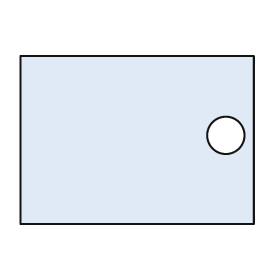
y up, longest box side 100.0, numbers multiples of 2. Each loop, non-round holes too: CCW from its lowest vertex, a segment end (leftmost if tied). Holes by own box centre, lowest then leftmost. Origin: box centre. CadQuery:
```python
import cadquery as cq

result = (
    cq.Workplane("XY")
    .moveTo(-50.0, -36.0)
    .lineTo(50.0, -36.0)
    .lineTo(50.0, 36.0)
    .lineTo(-50.0, 36.0)
    .close()
    .moveTo(38.0, 2.0)
    .circle(8.0)
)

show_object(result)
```